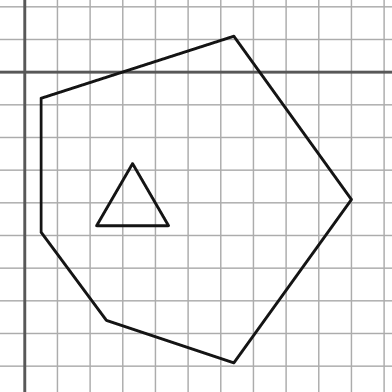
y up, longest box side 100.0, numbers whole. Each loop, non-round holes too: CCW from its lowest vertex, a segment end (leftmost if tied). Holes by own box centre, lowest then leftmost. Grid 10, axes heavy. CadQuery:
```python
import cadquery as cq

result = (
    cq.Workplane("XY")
    .moveTo(64.0, -89.0)
    .lineTo(100.0, -39.0)
    .lineTo(64.0, 11.0)
    .lineTo(5.0, -8.0)
    .lineTo(5.0, -49.0)
    .lineTo(25.0, -76.0)
    .close()
    .moveTo(22.0, -47.0)
    .lineTo(44.0, -47.0)
    .lineTo(33.0, -28.0)
    .close()
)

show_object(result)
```